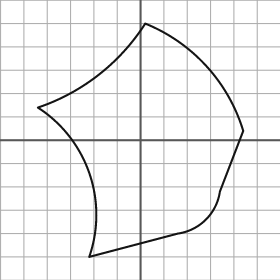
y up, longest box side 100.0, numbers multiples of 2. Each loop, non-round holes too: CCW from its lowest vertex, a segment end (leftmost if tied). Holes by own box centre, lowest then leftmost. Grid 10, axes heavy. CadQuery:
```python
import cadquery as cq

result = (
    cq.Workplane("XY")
    .moveTo(-22.0, -50.0)
    .lineTo(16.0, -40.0)
    .threePointArc((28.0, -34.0), (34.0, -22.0))
    .lineTo(44.0, 4.0)
    .threePointArc((28.0, 32.0), (2.0, 50.0))
    .threePointArc((-18.0, 28.0), (-44.0, 14.0))
    .threePointArc((-22.0, -14.0), (-22.0, -50.0))
    .close()
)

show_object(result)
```